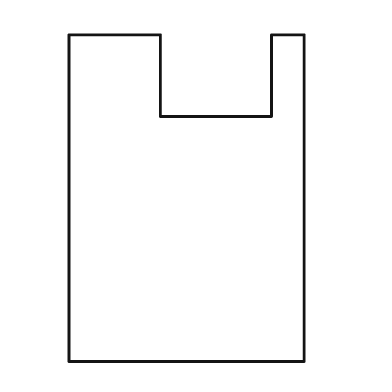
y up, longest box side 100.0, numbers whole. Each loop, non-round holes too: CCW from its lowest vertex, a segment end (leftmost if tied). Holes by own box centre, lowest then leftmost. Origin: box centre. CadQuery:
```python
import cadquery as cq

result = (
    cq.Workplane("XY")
    .moveTo(-36.0, -50.0)
    .lineTo(36.0, -50.0)
    .lineTo(36.0, 50.0)
    .lineTo(26.0, 50.0)
    .lineTo(26.0, 25.0)
    .lineTo(-8.0, 25.0)
    .lineTo(-8.0, 50.0)
    .lineTo(-36.0, 50.0)
    .close()
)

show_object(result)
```